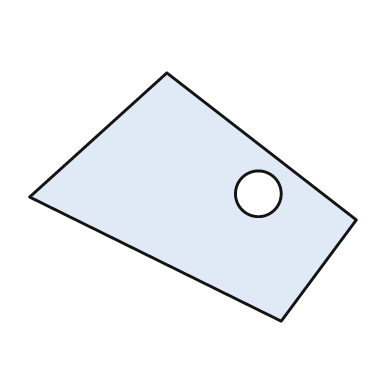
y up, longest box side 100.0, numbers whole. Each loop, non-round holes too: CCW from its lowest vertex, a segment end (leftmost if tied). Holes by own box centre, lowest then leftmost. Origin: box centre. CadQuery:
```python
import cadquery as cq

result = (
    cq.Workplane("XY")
    .moveTo(27.0, -38.0)
    .lineTo(50.0, -7.0)
    .lineTo(-8.0, 38.0)
    .lineTo(-50.0, 0.0)
    .close()
    .moveTo(20.0, 1.0)
    .circle(7.0)
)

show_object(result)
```